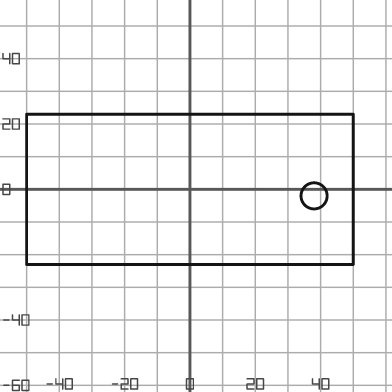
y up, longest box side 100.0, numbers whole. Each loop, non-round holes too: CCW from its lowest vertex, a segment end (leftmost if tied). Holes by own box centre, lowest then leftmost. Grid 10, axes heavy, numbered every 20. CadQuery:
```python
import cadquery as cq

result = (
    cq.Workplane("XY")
    .moveTo(-50.0, -23.0)
    .lineTo(50.0, -23.0)
    .lineTo(50.0, 23.0)
    .lineTo(-50.0, 23.0)
    .close()
    .moveTo(38.0, -2.0)
    .circle(4.0)
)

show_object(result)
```